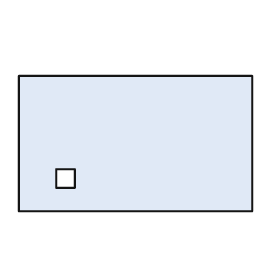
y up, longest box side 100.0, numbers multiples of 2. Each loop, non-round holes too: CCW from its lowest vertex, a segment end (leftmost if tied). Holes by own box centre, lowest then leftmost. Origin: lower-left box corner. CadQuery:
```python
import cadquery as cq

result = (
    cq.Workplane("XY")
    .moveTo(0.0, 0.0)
    .lineTo(100.0, 0.0)
    .lineTo(100.0, 58.0)
    .lineTo(0.0, 58.0)
    .close()
    .moveTo(16.0, 10.0)
    .lineTo(24.0, 10.0)
    .lineTo(24.0, 18.0)
    .lineTo(16.0, 18.0)
    .close()
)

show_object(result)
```